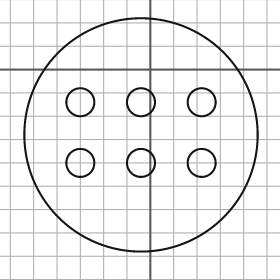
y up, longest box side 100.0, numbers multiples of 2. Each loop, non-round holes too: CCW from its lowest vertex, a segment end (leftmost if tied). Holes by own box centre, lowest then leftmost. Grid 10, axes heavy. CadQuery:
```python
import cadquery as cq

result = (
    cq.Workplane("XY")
    .moveTo(-4.0, -28.0)
    .circle(50.0)
    .moveTo(-30.0, -40.0)
    .circle(6.0)
    .moveTo(-4.0, -40.0)
    .circle(6.0)
    .moveTo(22.0, -40.0)
    .circle(6.0)
    .moveTo(-30.0, -14.0)
    .circle(6.0)
    .moveTo(-4.0, -14.0)
    .circle(6.0)
    .moveTo(22.0, -14.0)
    .circle(6.0)
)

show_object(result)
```